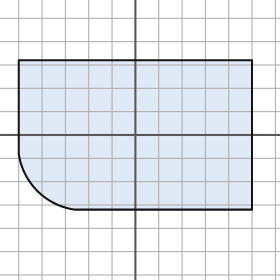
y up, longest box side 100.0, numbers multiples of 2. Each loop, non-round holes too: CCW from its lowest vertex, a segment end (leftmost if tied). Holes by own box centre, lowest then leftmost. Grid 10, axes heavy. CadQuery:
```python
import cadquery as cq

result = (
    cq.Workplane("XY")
    .moveTo(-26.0, -32.0)
    .lineTo(50.0, -32.0)
    .lineTo(50.0, 32.0)
    .lineTo(-50.0, 32.0)
    .lineTo(-50.0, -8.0)
    .threePointArc((-42.0, -24.0), (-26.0, -32.0))
    .close()
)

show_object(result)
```